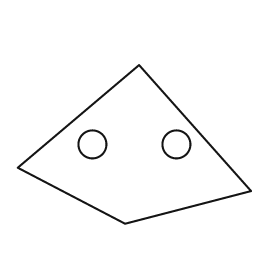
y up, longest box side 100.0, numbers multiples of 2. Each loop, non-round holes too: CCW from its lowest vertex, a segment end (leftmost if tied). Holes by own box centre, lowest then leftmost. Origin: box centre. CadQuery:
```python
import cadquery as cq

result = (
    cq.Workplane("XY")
    .moveTo(-4.0, -34.0)
    .lineTo(50.0, -20.0)
    .lineTo(2.0, 34.0)
    .lineTo(-50.0, -10.0)
    .close()
    .moveTo(-18.0, 0.0)
    .circle(6.0)
    .moveTo(18.0, 0.0)
    .circle(6.0)
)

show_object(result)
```